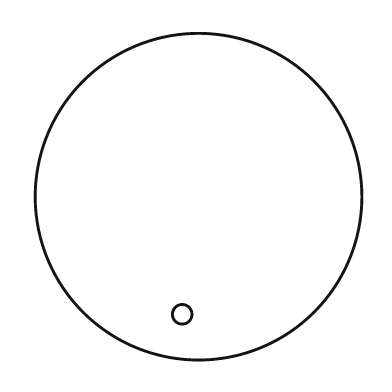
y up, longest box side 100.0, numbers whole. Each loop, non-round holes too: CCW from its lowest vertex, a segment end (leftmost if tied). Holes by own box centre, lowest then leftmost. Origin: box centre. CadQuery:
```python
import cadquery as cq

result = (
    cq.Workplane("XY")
    .moveTo(0.0, 0.0)
    .circle(50.0)
    .moveTo(-5.0, -36.0)
    .circle(3.0)
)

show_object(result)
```